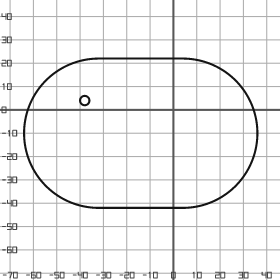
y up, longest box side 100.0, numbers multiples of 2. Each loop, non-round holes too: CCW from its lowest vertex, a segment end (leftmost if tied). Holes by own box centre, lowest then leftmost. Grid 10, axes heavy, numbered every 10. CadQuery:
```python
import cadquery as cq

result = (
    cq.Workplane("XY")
    .moveTo(-32.0, -42.0)
    .lineTo(4.0, -42.0)
    .threePointArc((36.0, -10.0), (4.0, 22.0))
    .lineTo(-32.0, 22.0)
    .threePointArc((-64.0, -10.0), (-32.0, -42.0))
    .close()
    .moveTo(-38.0, 4.0)
    .circle(2.0)
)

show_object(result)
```